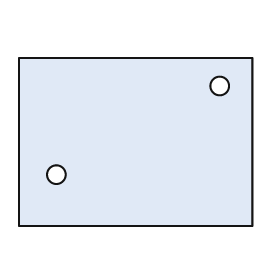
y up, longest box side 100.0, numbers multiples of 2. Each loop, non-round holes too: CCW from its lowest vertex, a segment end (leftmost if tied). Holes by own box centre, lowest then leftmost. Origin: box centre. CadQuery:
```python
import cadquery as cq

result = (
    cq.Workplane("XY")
    .moveTo(-50.0, -36.0)
    .lineTo(50.0, -36.0)
    .lineTo(50.0, 36.0)
    .lineTo(-50.0, 36.0)
    .close()
    .moveTo(-34.0, -14.0)
    .circle(4.0)
    .moveTo(36.0, 24.0)
    .circle(4.0)
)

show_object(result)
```